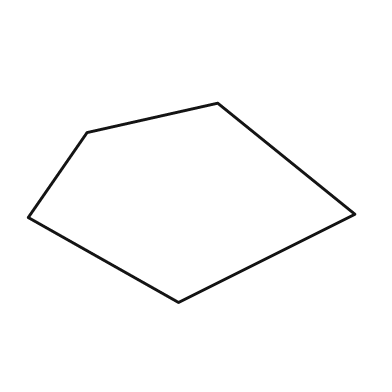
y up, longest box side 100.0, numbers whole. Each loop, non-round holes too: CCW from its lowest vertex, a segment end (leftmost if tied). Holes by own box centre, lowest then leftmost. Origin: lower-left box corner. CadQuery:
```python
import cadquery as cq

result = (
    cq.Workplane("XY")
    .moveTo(46.0, 0.0)
    .lineTo(100.0, 27.0)
    .lineTo(58.0, 61.0)
    .lineTo(18.0, 52.0)
    .lineTo(0.0, 26.0)
    .close()
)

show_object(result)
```